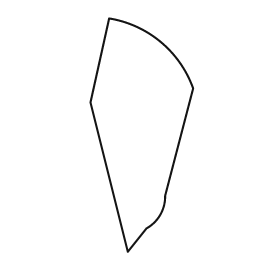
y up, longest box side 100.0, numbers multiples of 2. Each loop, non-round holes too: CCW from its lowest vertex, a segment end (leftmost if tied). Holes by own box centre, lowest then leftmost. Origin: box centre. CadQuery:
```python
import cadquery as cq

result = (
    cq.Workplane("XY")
    .moveTo(-6.0, -50.0)
    .lineTo(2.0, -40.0)
    .threePointArc((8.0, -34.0), (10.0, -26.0))
    .lineTo(22.0, 20.0)
    .threePointArc((8.0, 40.0), (-14.0, 50.0))
    .lineTo(-22.0, 14.0)
    .close()
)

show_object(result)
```